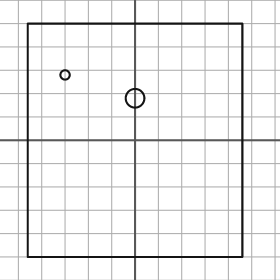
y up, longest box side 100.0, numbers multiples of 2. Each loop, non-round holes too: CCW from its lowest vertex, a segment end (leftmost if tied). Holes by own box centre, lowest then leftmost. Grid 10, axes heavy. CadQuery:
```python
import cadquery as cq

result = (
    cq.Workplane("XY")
    .moveTo(-46.0, -50.0)
    .lineTo(46.0, -50.0)
    .lineTo(46.0, 50.0)
    .lineTo(-46.0, 50.0)
    .close()
    .moveTo(0.0, 18.0)
    .circle(4.0)
    .moveTo(-30.0, 28.0)
    .circle(2.0)
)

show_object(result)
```